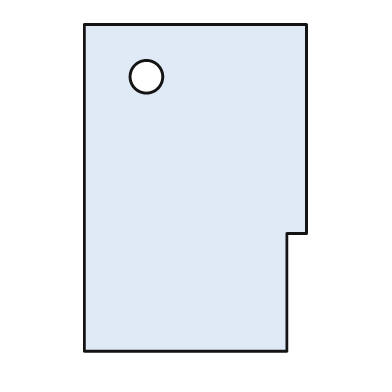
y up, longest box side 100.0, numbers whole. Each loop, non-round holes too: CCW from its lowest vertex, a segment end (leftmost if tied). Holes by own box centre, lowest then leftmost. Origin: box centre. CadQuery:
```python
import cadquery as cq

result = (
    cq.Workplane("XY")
    .moveTo(-34.0, -50.0)
    .lineTo(28.0, -50.0)
    .lineTo(28.0, -14.0)
    .lineTo(34.0, -14.0)
    .lineTo(34.0, 50.0)
    .lineTo(-34.0, 50.0)
    .close()
    .moveTo(-15.0, 34.0)
    .circle(5.0)
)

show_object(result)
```